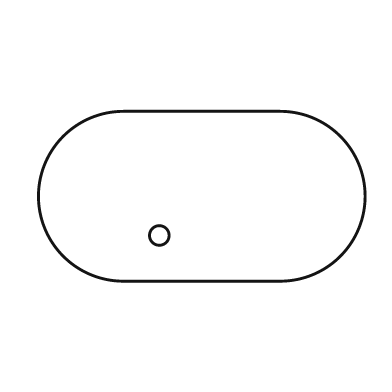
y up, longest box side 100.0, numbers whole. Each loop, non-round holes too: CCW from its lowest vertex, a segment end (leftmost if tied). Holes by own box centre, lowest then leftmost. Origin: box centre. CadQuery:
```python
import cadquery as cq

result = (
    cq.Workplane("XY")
    .moveTo(-24.0, -26.0)
    .lineTo(24.0, -26.0)
    .threePointArc((50.0, 0.0), (24.0, 26.0))
    .lineTo(-24.0, 26.0)
    .threePointArc((-50.0, 0.0), (-24.0, -26.0))
    .close()
    .moveTo(-13.0, -12.0)
    .circle(3.0)
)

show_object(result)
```